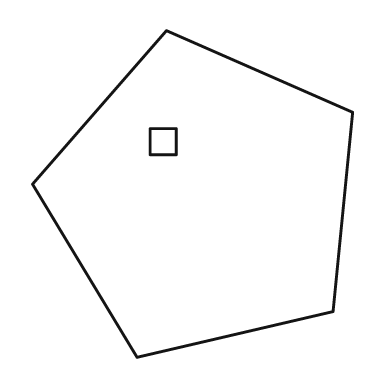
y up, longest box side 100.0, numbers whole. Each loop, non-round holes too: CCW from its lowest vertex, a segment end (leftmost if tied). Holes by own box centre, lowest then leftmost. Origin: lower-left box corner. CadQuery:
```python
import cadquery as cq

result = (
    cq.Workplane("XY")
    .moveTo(32.0, 0.0)
    .lineTo(92.0, 14.0)
    .lineTo(98.0, 75.0)
    .lineTo(41.0, 100.0)
    .lineTo(0.0, 53.0)
    .close()
    .moveTo(36.0, 62.0)
    .lineTo(44.0, 62.0)
    .lineTo(44.0, 70.0)
    .lineTo(36.0, 70.0)
    .close()
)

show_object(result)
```